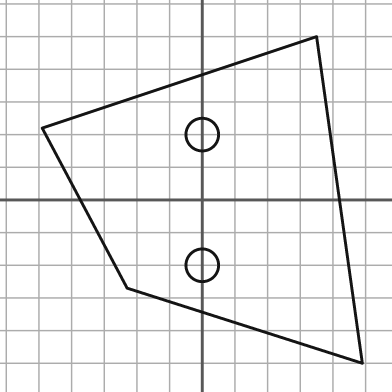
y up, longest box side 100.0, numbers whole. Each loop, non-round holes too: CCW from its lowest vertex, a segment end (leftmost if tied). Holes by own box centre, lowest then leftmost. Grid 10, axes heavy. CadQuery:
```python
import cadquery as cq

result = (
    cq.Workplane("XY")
    .moveTo(49.0, -50.0)
    .lineTo(35.0, 50.0)
    .lineTo(-49.0, 22.0)
    .lineTo(-23.0, -27.0)
    .close()
    .moveTo(0.0, -20.0)
    .circle(5.0)
    .moveTo(0.0, 20.0)
    .circle(5.0)
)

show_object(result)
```